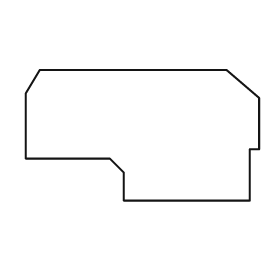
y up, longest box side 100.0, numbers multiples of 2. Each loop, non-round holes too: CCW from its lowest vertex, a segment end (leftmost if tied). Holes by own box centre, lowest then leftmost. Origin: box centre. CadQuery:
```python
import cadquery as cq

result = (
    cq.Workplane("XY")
    .moveTo(-8.0, -28.0)
    .lineTo(46.0, -28.0)
    .lineTo(46.0, -6.0)
    .lineTo(50.0, -6.0)
    .lineTo(50.0, 16.0)
    .lineTo(36.0, 28.0)
    .lineTo(-44.0, 28.0)
    .lineTo(-50.0, 18.0)
    .lineTo(-50.0, -10.0)
    .lineTo(-14.0, -10.0)
    .lineTo(-8.0, -16.0)
    .close()
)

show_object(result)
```